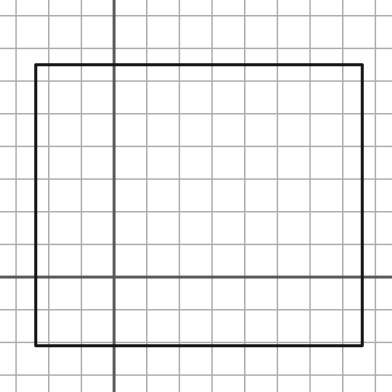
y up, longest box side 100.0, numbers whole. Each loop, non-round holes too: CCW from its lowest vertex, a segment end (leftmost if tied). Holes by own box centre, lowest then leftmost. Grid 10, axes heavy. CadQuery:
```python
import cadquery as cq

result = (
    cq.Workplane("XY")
    .moveTo(-24.0, -21.0)
    .lineTo(76.0, -21.0)
    .lineTo(76.0, 65.0)
    .lineTo(-24.0, 65.0)
    .close()
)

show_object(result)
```